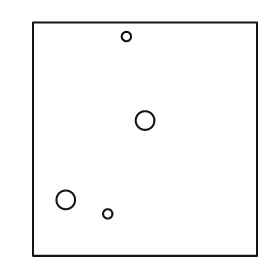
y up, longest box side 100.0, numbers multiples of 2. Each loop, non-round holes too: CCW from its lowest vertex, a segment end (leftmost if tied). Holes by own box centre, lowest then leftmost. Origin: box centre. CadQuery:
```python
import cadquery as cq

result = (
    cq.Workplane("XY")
    .moveTo(-48.0, -50.0)
    .lineTo(48.0, -50.0)
    .lineTo(48.0, 50.0)
    .lineTo(-48.0, 50.0)
    .close()
    .moveTo(-16.0, -32.0)
    .circle(2.0)
    .moveTo(-34.0, -26.0)
    .circle(4.0)
    .moveTo(0.0, 8.0)
    .circle(4.0)
    .moveTo(-8.0, 44.0)
    .circle(2.0)
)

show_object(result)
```